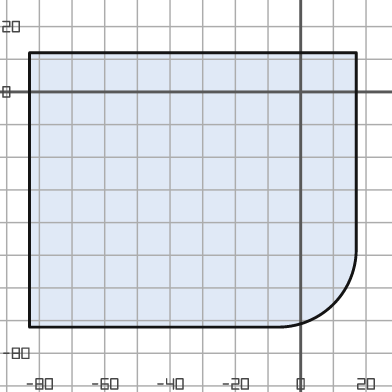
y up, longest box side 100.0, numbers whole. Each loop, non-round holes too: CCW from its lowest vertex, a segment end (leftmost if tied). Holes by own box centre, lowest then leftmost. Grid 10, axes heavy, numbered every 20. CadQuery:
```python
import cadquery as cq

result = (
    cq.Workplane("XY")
    .moveTo(-83.0, -72.0)
    .lineTo(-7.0, -72.0)
    .threePointArc((10.0, -65.0), (17.0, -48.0))
    .lineTo(17.0, 12.0)
    .lineTo(-83.0, 12.0)
    .close()
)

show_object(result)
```